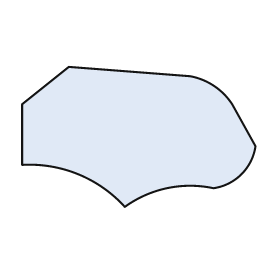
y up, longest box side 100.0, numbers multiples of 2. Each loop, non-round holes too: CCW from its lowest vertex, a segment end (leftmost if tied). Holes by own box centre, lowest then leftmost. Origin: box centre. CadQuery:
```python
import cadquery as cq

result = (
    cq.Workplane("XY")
    .moveTo(-6.0, -30.0)
    .threePointArc((12.0, -22.0), (32.0, -22.0))
    .threePointArc((44.0, -16.0), (50.0, -4.0))
    .lineTo(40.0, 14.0)
    .threePointArc((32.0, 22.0), (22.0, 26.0))
    .lineTo(-30.0, 30.0)
    .lineTo(-50.0, 14.0)
    .lineTo(-50.0, -12.0)
    .threePointArc((-26.0, -16.0), (-6.0, -30.0))
    .close()
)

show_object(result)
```